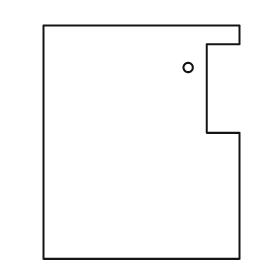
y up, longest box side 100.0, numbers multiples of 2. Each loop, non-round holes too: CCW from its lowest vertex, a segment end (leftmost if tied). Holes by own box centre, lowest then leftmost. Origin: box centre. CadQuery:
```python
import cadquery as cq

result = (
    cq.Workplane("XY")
    .moveTo(-42.0, -50.0)
    .lineTo(42.0, -50.0)
    .lineTo(42.0, 4.0)
    .lineTo(28.0, 4.0)
    .lineTo(28.0, 42.0)
    .lineTo(42.0, 42.0)
    .lineTo(42.0, 50.0)
    .lineTo(-42.0, 50.0)
    .close()
    .moveTo(20.0, 32.0)
    .circle(2.0)
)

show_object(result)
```